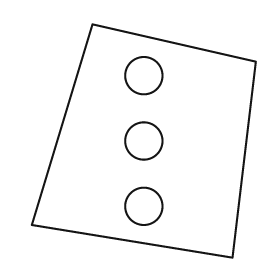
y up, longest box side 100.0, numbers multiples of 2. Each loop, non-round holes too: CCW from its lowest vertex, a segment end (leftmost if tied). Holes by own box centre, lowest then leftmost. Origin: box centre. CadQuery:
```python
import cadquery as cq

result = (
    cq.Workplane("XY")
    .moveTo(38.0, -50.0)
    .lineTo(48.0, 34.0)
    .lineTo(-22.0, 50.0)
    .lineTo(-48.0, -36.0)
    .close()
    .moveTo(0.0, -28.0)
    .circle(8.0)
    .moveTo(0.0, 0.0)
    .circle(8.0)
    .moveTo(0.0, 28.0)
    .circle(8.0)
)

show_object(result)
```